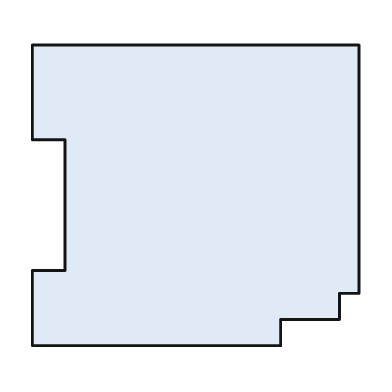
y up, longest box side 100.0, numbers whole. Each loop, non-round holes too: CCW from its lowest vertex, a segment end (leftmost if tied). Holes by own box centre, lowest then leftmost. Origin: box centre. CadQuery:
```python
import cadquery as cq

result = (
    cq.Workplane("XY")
    .moveTo(-50.0, -46.0)
    .lineTo(26.0, -46.0)
    .lineTo(26.0, -38.0)
    .lineTo(44.0, -38.0)
    .lineTo(44.0, -30.0)
    .lineTo(50.0, -30.0)
    .lineTo(50.0, 46.0)
    .lineTo(-50.0, 46.0)
    .lineTo(-50.0, 17.0)
    .lineTo(-40.0, 17.0)
    .lineTo(-40.0, -23.0)
    .lineTo(-50.0, -23.0)
    .close()
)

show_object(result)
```